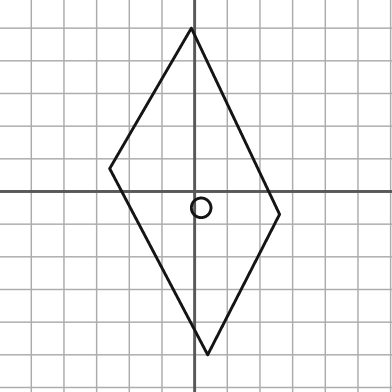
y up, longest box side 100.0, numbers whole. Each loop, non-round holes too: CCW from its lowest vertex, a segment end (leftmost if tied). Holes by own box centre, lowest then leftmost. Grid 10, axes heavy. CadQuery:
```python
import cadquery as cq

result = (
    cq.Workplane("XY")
    .moveTo(4.0, -50.0)
    .lineTo(26.0, -7.0)
    .lineTo(-1.0, 50.0)
    .lineTo(-26.0, 7.0)
    .close()
    .moveTo(2.0, -5.0)
    .circle(3.0)
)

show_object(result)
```